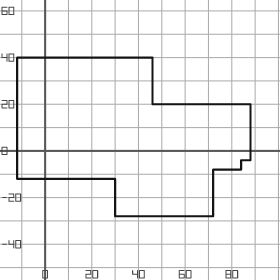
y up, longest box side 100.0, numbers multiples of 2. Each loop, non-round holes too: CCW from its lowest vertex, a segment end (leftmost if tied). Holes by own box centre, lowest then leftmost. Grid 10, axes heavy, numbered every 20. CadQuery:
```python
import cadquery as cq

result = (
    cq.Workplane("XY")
    .moveTo(30.0, -28.0)
    .lineTo(72.0, -28.0)
    .lineTo(72.0, -8.0)
    .lineTo(84.0, -8.0)
    .lineTo(84.0, -4.0)
    .lineTo(88.0, -4.0)
    .lineTo(88.0, 20.0)
    .lineTo(46.0, 20.0)
    .lineTo(46.0, 40.0)
    .lineTo(-12.0, 40.0)
    .lineTo(-12.0, -12.0)
    .lineTo(30.0, -12.0)
    .close()
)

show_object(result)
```